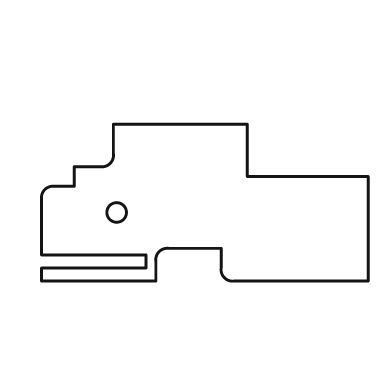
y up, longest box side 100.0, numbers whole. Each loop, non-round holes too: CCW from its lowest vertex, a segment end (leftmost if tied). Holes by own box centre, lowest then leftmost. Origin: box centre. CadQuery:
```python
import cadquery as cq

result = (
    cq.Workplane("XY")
    .moveTo(-50.0, -24.0)
    .lineTo(-15.0, -24.0)
    .lineTo(-15.0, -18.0)
    .threePointArc((-14.0, -15.0), (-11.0, -14.0))
    .lineTo(5.0, -14.0)
    .lineTo(5.0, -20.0)
    .threePointArc((6.0, -23.0), (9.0, -24.0))
    .lineTo(50.0, -24.0)
    .lineTo(50.0, 8.0)
    .lineTo(13.0, 8.0)
    .lineTo(13.0, 24.0)
    .lineTo(-28.0, 24.0)
    .lineTo(-28.0, 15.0)
    .threePointArc((-29.0, 12.0), (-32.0, 11.0))
    .lineTo(-40.0, 11.0)
    .lineTo(-40.0, 5.0)
    .lineTo(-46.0, 5.0)
    .threePointArc((-49.0, 4.0), (-50.0, 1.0))
    .lineTo(-50.0, -16.0)
    .lineTo(-18.0, -16.0)
    .lineTo(-18.0, -20.0)
    .lineTo(-50.0, -20.0)
    .close()
    .moveTo(-27.0, -3.0)
    .circle(3.0)
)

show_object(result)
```